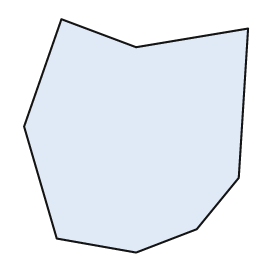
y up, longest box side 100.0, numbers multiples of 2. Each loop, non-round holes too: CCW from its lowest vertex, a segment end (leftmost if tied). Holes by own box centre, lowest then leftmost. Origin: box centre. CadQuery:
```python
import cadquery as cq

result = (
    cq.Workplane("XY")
    .moveTo(0.0, -50.0)
    .lineTo(26.0, -40.0)
    .lineTo(44.0, -18.0)
    .lineTo(48.0, 46.0)
    .lineTo(0.0, 38.0)
    .lineTo(-32.0, 50.0)
    .lineTo(-48.0, 4.0)
    .lineTo(-34.0, -44.0)
    .close()
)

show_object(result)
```